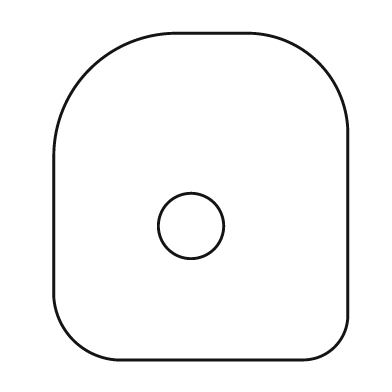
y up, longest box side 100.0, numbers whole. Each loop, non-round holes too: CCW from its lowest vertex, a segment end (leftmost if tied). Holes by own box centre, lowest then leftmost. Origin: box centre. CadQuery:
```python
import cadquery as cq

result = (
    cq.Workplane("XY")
    .moveTo(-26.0, -50.0)
    .lineTo(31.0, -50.0)
    .threePointArc((41.0, -46.0), (45.0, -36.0))
    .lineTo(45.0, 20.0)
    .threePointArc((36.0, 41.0), (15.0, 50.0))
    .lineTo(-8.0, 50.0)
    .threePointArc((-34.0, 39.0), (-45.0, 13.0))
    .lineTo(-45.0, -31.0)
    .threePointArc((-39.0, -44.0), (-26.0, -50.0))
    .close()
    .moveTo(-3.0, -9.0)
    .circle(10.0)
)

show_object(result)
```